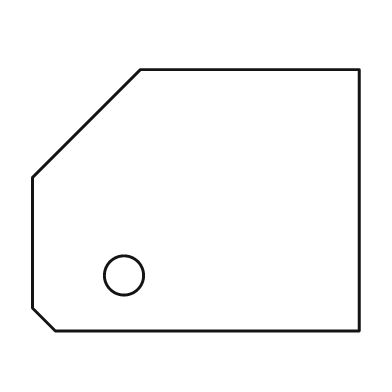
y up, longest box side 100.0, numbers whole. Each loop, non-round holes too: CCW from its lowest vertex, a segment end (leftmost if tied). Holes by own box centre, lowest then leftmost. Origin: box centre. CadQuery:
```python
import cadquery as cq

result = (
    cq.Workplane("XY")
    .moveTo(-43.0, -40.0)
    .lineTo(50.0, -40.0)
    .lineTo(50.0, 40.0)
    .lineTo(-17.0, 40.0)
    .lineTo(-50.0, 7.0)
    .lineTo(-50.0, -33.0)
    .close()
    .moveTo(-22.0, -23.0)
    .circle(6.0)
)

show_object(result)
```